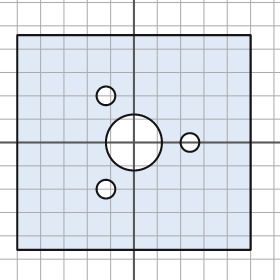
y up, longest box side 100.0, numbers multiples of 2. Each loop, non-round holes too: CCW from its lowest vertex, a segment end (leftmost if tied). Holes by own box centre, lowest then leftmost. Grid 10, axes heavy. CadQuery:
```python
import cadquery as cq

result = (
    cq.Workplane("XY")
    .moveTo(-50.0, -46.0)
    .lineTo(50.0, -46.0)
    .lineTo(50.0, 46.0)
    .lineTo(-50.0, 46.0)
    .close()
    .moveTo(-12.0, -20.0)
    .circle(4.0)
    .moveTo(0.0, 0.0)
    .circle(12.0)
    .moveTo(24.0, 0.0)
    .circle(4.0)
    .moveTo(-12.0, 20.0)
    .circle(4.0)
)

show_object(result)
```